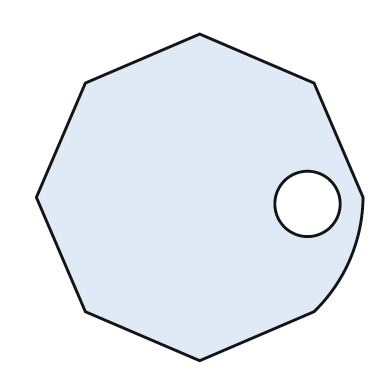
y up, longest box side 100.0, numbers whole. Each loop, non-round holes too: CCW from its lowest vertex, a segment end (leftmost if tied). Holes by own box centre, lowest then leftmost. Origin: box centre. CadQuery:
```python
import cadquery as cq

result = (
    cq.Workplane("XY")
    .moveTo(0.0, -50.0)
    .lineTo(35.0, -35.0)
    .threePointArc((46.0, -19.0), (50.0, 0.0))
    .lineTo(35.0, 35.0)
    .lineTo(0.0, 50.0)
    .lineTo(-35.0, 35.0)
    .lineTo(-50.0, 0.0)
    .lineTo(-35.0, -35.0)
    .close()
    .moveTo(33.0, -2.0)
    .circle(10.0)
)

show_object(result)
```